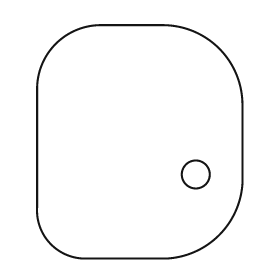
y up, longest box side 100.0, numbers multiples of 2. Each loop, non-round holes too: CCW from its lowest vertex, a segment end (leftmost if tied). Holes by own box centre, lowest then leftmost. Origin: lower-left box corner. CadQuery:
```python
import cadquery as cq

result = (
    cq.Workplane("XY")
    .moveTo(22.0, 0.0)
    .lineTo(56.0, 0.0)
    .threePointArc((78.0, 10.0), (88.0, 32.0))
    .lineTo(88.0, 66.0)
    .threePointArc((78.0, 90.0), (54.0, 100.0))
    .lineTo(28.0, 100.0)
    .threePointArc((8.0, 92.0), (0.0, 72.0))
    .lineTo(0.0, 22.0)
    .threePointArc((6.0, 6.0), (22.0, 0.0))
    .close()
    .moveTo(68.0, 36.0)
    .circle(6.0)
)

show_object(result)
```